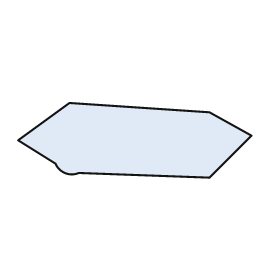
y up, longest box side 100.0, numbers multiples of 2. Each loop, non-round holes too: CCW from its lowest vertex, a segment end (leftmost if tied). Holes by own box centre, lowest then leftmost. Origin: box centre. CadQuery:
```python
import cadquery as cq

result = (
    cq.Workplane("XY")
    .moveTo(32.0, -16.0)
    .lineTo(50.0, 2.0)
    .lineTo(32.0, 12.0)
    .lineTo(-28.0, 16.0)
    .lineTo(-50.0, 0.0)
    .lineTo(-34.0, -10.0)
    .threePointArc((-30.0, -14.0), (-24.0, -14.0))
    .close()
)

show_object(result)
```